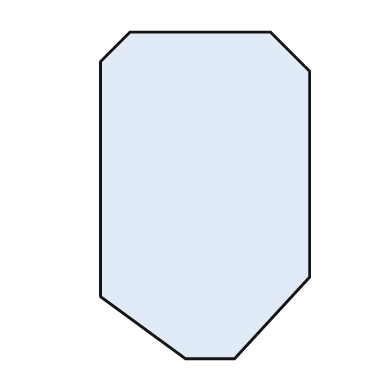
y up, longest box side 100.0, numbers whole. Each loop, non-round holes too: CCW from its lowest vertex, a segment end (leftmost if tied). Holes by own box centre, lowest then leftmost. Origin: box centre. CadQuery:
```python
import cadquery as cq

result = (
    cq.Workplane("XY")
    .moveTo(-6.0, -50.0)
    .lineTo(9.0, -50.0)
    .lineTo(32.0, -25.0)
    .lineTo(32.0, 38.0)
    .lineTo(20.0, 50.0)
    .lineTo(-23.0, 50.0)
    .lineTo(-32.0, 41.0)
    .lineTo(-32.0, -31.0)
    .close()
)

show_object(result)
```